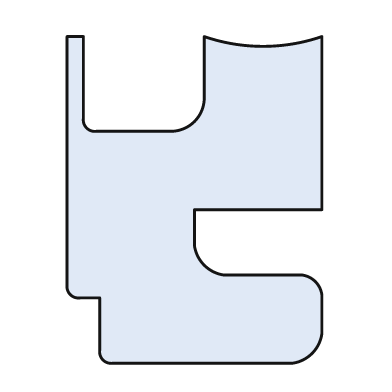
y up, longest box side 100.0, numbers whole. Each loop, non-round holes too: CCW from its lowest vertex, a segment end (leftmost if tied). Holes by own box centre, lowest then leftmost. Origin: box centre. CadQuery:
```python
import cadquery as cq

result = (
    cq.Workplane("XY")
    .moveTo(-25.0, -50.0)
    .lineTo(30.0, -50.0)
    .threePointArc((36.0, -47.0), (39.0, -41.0))
    .lineTo(39.0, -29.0)
    .threePointArc((37.0, -25.0), (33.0, -23.0))
    .lineTo(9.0, -23.0)
    .threePointArc((3.0, -20.0), (0.0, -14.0))
    .lineTo(0.0, -3.0)
    .lineTo(39.0, -3.0)
    .lineTo(39.0, 50.0)
    .threePointArc((21.0, 47.0), (3.0, 50.0))
    .lineTo(3.0, 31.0)
    .threePointArc((0.0, 24.0), (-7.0, 21.0))
    .lineTo(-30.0, 21.0)
    .threePointArc((-33.0, 22.0), (-34.0, 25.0))
    .lineTo(-34.0, 50.0)
    .lineTo(-39.0, 50.0)
    .lineTo(-39.0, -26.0)
    .threePointArc((-38.0, -29.0), (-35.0, -30.0))
    .lineTo(-29.0, -30.0)
    .lineTo(-29.0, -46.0)
    .threePointArc((-28.0, -49.0), (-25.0, -50.0))
    .close()
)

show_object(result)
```